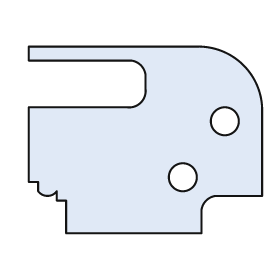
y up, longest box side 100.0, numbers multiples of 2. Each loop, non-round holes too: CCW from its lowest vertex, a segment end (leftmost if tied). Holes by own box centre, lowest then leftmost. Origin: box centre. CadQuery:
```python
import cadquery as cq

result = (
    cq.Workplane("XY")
    .moveTo(-34.0, -40.0)
    .lineTo(24.0, -40.0)
    .lineTo(24.0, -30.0)
    .threePointArc((26.0, -26.0), (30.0, -24.0))
    .lineTo(50.0, -24.0)
    .lineTo(50.0, 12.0)
    .threePointArc((42.0, 32.0), (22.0, 40.0))
    .lineTo(-50.0, 40.0)
    .lineTo(-50.0, 34.0)
    .lineTo(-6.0, 34.0)
    .threePointArc((-2.0, 32.0), (0.0, 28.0))
    .lineTo(0.0, 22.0)
    .threePointArc((-2.0, 16.0), (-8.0, 14.0))
    .lineTo(-50.0, 14.0)
    .lineTo(-50.0, -18.0)
    .lineTo(-46.0, -18.0)
    .lineTo(-46.0, -22.0)
    .threePointArc((-42.0, -24.0), (-38.0, -22.0))
    .lineTo(-38.0, -26.0)
    .lineTo(-34.0, -26.0)
    .close()
    .moveTo(16.0, -16.0)
    .circle(6.0)
    .moveTo(34.0, 8.0)
    .circle(6.0)
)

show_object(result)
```